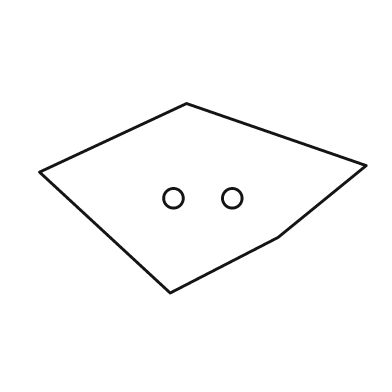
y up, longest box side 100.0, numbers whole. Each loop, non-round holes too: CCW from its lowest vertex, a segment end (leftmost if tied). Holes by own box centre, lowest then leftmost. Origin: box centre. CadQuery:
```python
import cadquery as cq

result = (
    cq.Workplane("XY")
    .moveTo(-10.0, -29.0)
    .lineTo(23.0, -12.0)
    .lineTo(50.0, 10.0)
    .lineTo(-5.0, 29.0)
    .lineTo(-50.0, 8.0)
    .close()
    .moveTo(-9.0, 0.0)
    .circle(3.0)
    .moveTo(9.0, 0.0)
    .circle(3.0)
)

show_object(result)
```